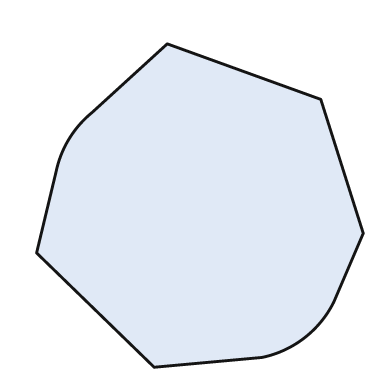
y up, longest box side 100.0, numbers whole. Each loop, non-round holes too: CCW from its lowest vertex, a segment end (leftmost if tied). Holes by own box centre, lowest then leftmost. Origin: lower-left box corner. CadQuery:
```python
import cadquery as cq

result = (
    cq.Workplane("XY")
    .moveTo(36.0, 0.0)
    .lineTo(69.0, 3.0)
    .threePointArc((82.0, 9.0), (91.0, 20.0))
    .lineTo(100.0, 41.0)
    .lineTo(87.0, 82.0)
    .lineTo(40.0, 99.0)
    .lineTo(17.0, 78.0)
    .threePointArc((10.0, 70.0), (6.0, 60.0))
    .lineTo(0.0, 35.0)
    .close()
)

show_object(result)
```